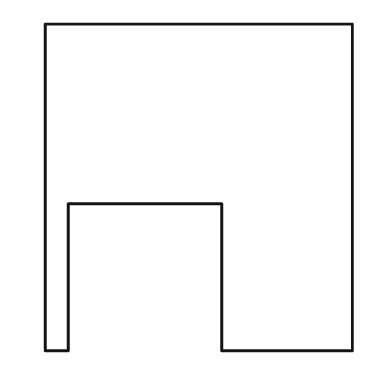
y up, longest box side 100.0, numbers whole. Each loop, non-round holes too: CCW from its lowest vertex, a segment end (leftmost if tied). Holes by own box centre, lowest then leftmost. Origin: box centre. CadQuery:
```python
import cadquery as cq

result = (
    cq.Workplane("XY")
    .moveTo(-47.0, -50.0)
    .lineTo(-40.0, -50.0)
    .lineTo(-40.0, -5.0)
    .lineTo(7.0, -5.0)
    .lineTo(7.0, -50.0)
    .lineTo(47.0, -50.0)
    .lineTo(47.0, 50.0)
    .lineTo(-47.0, 50.0)
    .close()
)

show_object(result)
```